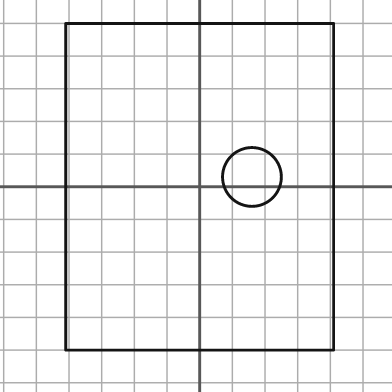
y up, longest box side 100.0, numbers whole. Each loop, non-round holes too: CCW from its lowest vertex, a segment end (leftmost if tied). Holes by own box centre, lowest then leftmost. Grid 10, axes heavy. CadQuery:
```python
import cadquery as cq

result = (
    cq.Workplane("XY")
    .moveTo(-41.0, -50.0)
    .lineTo(41.0, -50.0)
    .lineTo(41.0, 50.0)
    .lineTo(-41.0, 50.0)
    .close()
    .moveTo(16.0, 3.0)
    .circle(9.0)
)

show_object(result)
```